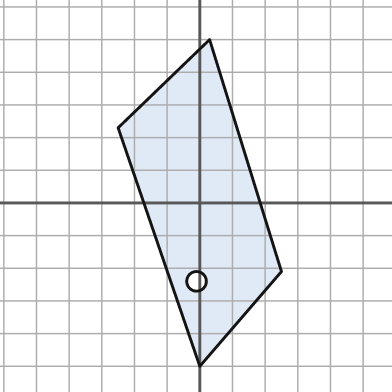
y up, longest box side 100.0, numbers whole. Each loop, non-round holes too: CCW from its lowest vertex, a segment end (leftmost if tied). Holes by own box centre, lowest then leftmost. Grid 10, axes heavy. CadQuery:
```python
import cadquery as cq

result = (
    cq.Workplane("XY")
    .moveTo(0.0, -50.0)
    .lineTo(25.0, -21.0)
    .lineTo(3.0, 50.0)
    .lineTo(-25.0, 23.0)
    .close()
    .moveTo(-1.0, -24.0)
    .circle(3.0)
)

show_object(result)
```